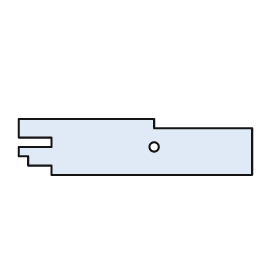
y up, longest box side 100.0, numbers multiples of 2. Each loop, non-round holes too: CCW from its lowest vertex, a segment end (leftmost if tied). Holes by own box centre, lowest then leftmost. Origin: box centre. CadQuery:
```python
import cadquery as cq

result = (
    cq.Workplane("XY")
    .moveTo(-36.0, -12.0)
    .lineTo(50.0, -12.0)
    .lineTo(50.0, 8.0)
    .lineTo(8.0, 8.0)
    .lineTo(8.0, 12.0)
    .lineTo(-50.0, 12.0)
    .lineTo(-50.0, 4.0)
    .lineTo(-36.0, 4.0)
    .lineTo(-36.0, 0.0)
    .lineTo(-50.0, 0.0)
    .lineTo(-50.0, -4.0)
    .lineTo(-46.0, -4.0)
    .lineTo(-46.0, -8.0)
    .lineTo(-36.0, -8.0)
    .close()
    .moveTo(8.0, 0.0)
    .circle(2.0)
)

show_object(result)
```